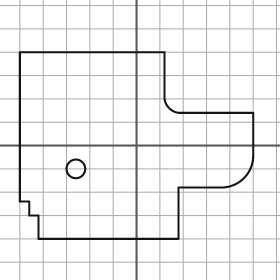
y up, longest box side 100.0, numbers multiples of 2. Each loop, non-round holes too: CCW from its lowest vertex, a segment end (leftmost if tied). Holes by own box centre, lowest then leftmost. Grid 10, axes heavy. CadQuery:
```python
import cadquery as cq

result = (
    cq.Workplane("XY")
    .moveTo(-42.0, -40.0)
    .lineTo(18.0, -40.0)
    .lineTo(18.0, -18.0)
    .lineTo(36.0, -18.0)
    .threePointArc((46.0, -14.0), (50.0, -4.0))
    .lineTo(50.0, 14.0)
    .lineTo(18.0, 14.0)
    .threePointArc((14.0, 16.0), (12.0, 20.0))
    .lineTo(12.0, 40.0)
    .lineTo(-50.0, 40.0)
    .lineTo(-50.0, -24.0)
    .lineTo(-46.0, -24.0)
    .lineTo(-46.0, -30.0)
    .lineTo(-42.0, -30.0)
    .close()
    .moveTo(-26.0, -10.0)
    .circle(4.0)
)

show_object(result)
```